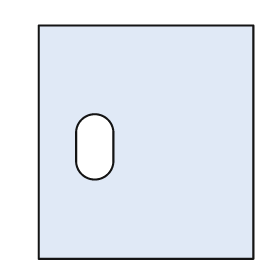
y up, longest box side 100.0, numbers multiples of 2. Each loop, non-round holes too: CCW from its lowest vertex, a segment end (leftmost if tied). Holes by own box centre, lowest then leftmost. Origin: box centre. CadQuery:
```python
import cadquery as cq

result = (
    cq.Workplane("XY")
    .moveTo(-46.0, -50.0)
    .lineTo(46.0, -50.0)
    .lineTo(46.0, 50.0)
    .lineTo(-46.0, 50.0)
    .close()
    .moveTo(-30.0, -8.0)
    .threePointArc((-22.0, -16.0), (-14.0, -8.0))
    .lineTo(-14.0, 4.0)
    .threePointArc((-22.0, 12.0), (-30.0, 4.0))
    .close()
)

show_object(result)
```